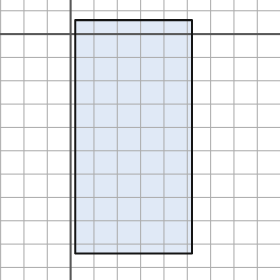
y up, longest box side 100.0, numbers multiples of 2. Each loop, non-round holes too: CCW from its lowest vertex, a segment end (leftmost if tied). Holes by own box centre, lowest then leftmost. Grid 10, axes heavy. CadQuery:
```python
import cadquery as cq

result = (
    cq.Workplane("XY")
    .moveTo(2.0, -94.0)
    .lineTo(52.0, -94.0)
    .lineTo(52.0, 6.0)
    .lineTo(2.0, 6.0)
    .close()
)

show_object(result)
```